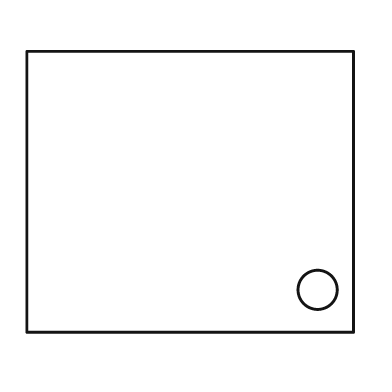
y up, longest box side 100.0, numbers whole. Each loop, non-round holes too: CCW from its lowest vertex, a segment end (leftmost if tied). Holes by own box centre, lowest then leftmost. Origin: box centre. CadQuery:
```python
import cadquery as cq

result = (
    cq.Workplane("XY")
    .moveTo(-50.0, -43.0)
    .lineTo(50.0, -43.0)
    .lineTo(50.0, 43.0)
    .lineTo(-50.0, 43.0)
    .close()
    .moveTo(39.0, -30.0)
    .circle(6.0)
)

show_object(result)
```